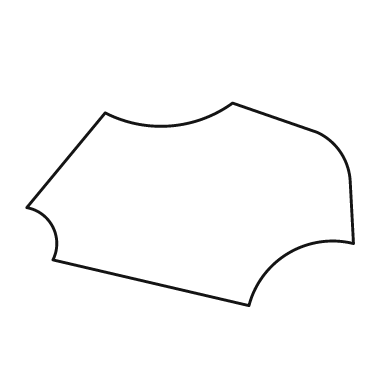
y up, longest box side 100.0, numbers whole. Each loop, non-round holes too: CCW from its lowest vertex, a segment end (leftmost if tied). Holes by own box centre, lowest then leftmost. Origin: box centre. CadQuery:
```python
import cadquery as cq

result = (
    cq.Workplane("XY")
    .moveTo(18.0, -31.0)
    .threePointArc((30.0, -15.0), (50.0, -12.0))
    .lineTo(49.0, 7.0)
    .threePointArc((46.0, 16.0), (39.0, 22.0))
    .lineTo(13.0, 31.0)
    .threePointArc((-6.0, 24.0), (-26.0, 28.0))
    .lineTo(-50.0, -1.0)
    .threePointArc((-42.0, -7.0), (-42.0, -17.0))
    .close()
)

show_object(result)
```